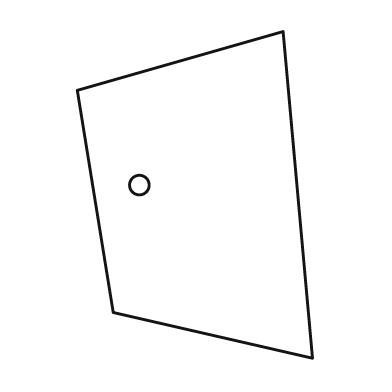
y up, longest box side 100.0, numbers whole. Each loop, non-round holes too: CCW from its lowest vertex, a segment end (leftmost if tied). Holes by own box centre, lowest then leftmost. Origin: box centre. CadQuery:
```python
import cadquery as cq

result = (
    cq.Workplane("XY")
    .moveTo(36.0, -50.0)
    .lineTo(27.0, 50.0)
    .lineTo(-36.0, 32.0)
    .lineTo(-25.0, -36.0)
    .close()
    .moveTo(-17.0, 3.0)
    .circle(3.0)
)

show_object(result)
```